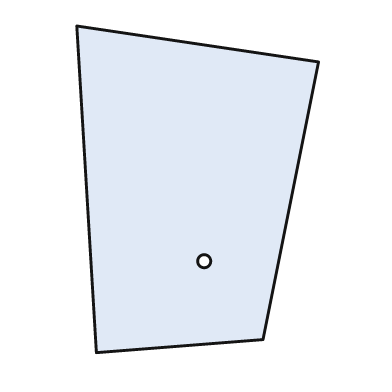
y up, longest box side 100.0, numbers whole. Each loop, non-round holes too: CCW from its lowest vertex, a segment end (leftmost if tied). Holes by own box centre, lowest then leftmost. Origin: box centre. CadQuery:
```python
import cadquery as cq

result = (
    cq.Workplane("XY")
    .moveTo(-31.0, -50.0)
    .lineTo(20.0, -46.0)
    .lineTo(37.0, 39.0)
    .lineTo(-37.0, 50.0)
    .close()
    .moveTo(2.0, -22.0)
    .circle(2.0)
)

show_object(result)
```